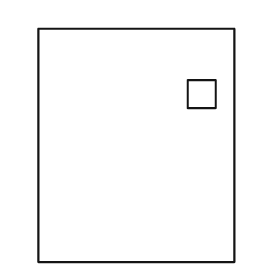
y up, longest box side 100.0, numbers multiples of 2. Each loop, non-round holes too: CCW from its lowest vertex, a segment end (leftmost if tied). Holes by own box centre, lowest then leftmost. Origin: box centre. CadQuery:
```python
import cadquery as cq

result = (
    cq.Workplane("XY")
    .moveTo(-42.0, -50.0)
    .lineTo(42.0, -50.0)
    .lineTo(42.0, 50.0)
    .lineTo(-42.0, 50.0)
    .close()
    .moveTo(22.0, 16.0)
    .lineTo(34.0, 16.0)
    .lineTo(34.0, 28.0)
    .lineTo(22.0, 28.0)
    .close()
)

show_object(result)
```